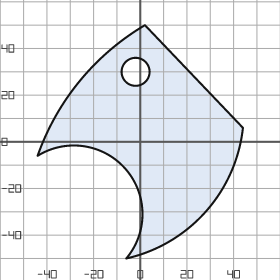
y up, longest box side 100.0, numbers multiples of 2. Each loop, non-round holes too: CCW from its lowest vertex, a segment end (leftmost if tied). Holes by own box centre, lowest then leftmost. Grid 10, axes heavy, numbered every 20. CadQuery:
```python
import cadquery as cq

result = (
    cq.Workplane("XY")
    .moveTo(-6.0, -50.0)
    .threePointArc((28.0, -30.0), (44.0, 6.0))
    .lineTo(2.0, 50.0)
    .threePointArc((-26.0, 26.0), (-44.0, -6.0))
    .threePointArc((-6.0, -12.0), (-6.0, -50.0))
    .close()
    .moveTo(-2.0, 30.0)
    .circle(6.0)
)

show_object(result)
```